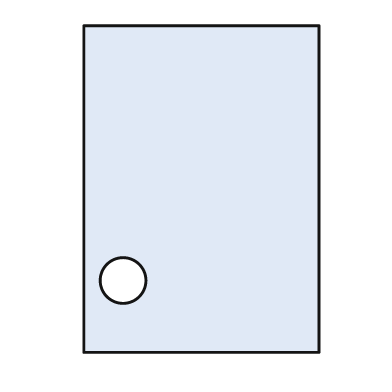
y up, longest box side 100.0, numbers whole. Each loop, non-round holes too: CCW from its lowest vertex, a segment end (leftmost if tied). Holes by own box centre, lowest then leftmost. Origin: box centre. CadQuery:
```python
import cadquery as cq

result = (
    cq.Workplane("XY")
    .moveTo(-36.0, -50.0)
    .lineTo(36.0, -50.0)
    .lineTo(36.0, 50.0)
    .lineTo(-36.0, 50.0)
    .close()
    .moveTo(-24.0, -28.0)
    .circle(7.0)
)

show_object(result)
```